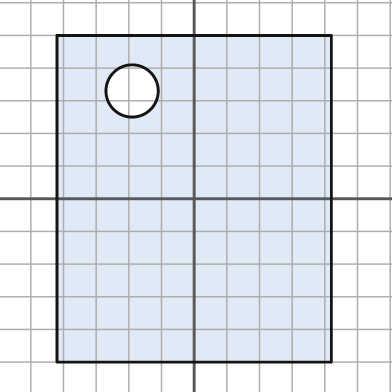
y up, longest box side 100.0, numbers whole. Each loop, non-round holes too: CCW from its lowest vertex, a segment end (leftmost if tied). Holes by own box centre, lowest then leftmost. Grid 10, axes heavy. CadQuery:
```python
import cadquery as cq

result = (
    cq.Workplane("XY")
    .moveTo(-42.0, -50.0)
    .lineTo(42.0, -50.0)
    .lineTo(42.0, 50.0)
    .lineTo(-42.0, 50.0)
    .close()
    .moveTo(-19.0, 33.0)
    .circle(8.0)
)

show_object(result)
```